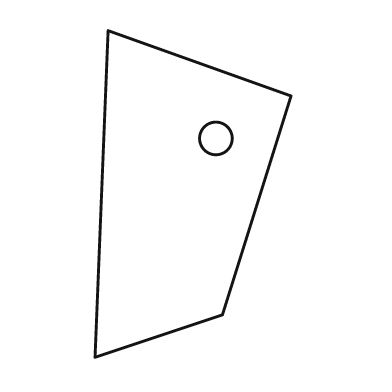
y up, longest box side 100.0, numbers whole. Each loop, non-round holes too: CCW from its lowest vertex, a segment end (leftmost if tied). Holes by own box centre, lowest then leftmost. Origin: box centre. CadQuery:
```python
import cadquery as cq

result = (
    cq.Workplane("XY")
    .moveTo(-30.0, -50.0)
    .lineTo(9.0, -37.0)
    .lineTo(30.0, 30.0)
    .lineTo(-26.0, 50.0)
    .close()
    .moveTo(7.0, 17.0)
    .circle(5.0)
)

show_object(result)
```